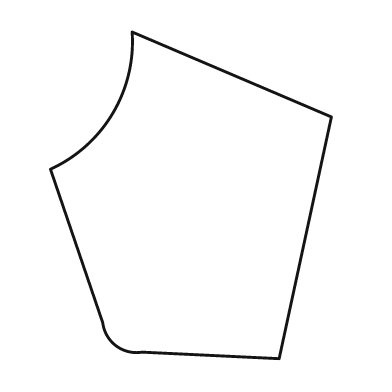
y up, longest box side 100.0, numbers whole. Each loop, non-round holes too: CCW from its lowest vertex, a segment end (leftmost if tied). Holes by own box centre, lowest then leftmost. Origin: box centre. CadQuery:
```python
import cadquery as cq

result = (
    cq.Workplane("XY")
    .moveTo(27.0, -50.0)
    .lineTo(43.0, 24.0)
    .lineTo(-18.0, 50.0)
    .threePointArc((-24.0, 25.0), (-43.0, 8.0))
    .lineTo(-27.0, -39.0)
    .threePointArc((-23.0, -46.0), (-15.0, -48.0))
    .close()
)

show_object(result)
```